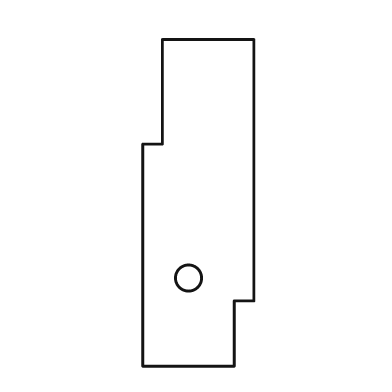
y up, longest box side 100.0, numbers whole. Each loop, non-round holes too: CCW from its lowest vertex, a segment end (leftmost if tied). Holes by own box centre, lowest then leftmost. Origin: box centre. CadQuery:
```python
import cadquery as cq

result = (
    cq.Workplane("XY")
    .moveTo(-17.0, -50.0)
    .lineTo(11.0, -50.0)
    .lineTo(11.0, -30.0)
    .lineTo(17.0, -30.0)
    .lineTo(17.0, 50.0)
    .lineTo(-11.0, 50.0)
    .lineTo(-11.0, 18.0)
    .lineTo(-17.0, 18.0)
    .close()
    .moveTo(-3.0, -23.0)
    .circle(4.0)
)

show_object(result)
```